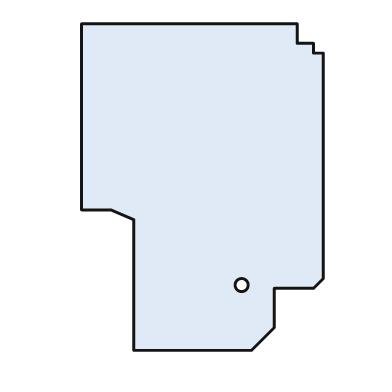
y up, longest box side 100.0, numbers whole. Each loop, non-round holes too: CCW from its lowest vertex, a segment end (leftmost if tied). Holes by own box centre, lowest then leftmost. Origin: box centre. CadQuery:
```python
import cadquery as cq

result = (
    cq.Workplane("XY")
    .moveTo(-21.0, -50.0)
    .lineTo(15.0, -50.0)
    .lineTo(22.0, -43.0)
    .lineTo(22.0, -31.0)
    .lineTo(34.0, -31.0)
    .lineTo(37.0, -28.0)
    .lineTo(37.0, 41.0)
    .lineTo(34.0, 41.0)
    .lineTo(34.0, 44.0)
    .lineTo(29.0, 44.0)
    .lineTo(29.0, 50.0)
    .lineTo(-37.0, 50.0)
    .lineTo(-37.0, -7.0)
    .lineTo(-28.0, -7.0)
    .lineTo(-21.0, -10.0)
    .close()
    .moveTo(12.0, -30.0)
    .circle(2.0)
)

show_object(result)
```